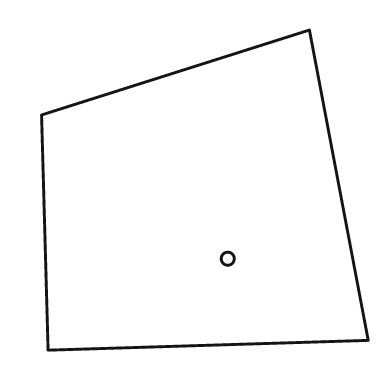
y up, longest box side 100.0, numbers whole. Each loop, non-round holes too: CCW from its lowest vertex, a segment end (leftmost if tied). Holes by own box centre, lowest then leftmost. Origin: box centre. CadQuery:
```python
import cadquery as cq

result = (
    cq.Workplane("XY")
    .moveTo(-48.0, -49.0)
    .lineTo(50.0, -46.0)
    .lineTo(32.0, 49.0)
    .lineTo(-50.0, 23.0)
    .close()
    .moveTo(7.0, -21.0)
    .circle(2.0)
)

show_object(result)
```